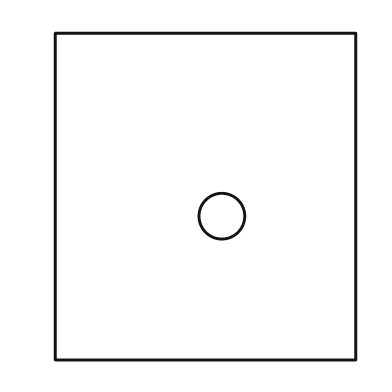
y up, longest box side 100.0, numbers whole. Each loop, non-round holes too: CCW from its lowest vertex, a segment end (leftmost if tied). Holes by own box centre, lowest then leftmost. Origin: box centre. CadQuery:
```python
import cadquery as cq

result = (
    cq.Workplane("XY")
    .moveTo(-46.0, -50.0)
    .lineTo(46.0, -50.0)
    .lineTo(46.0, 50.0)
    .lineTo(-46.0, 50.0)
    .close()
    .moveTo(5.0, -6.0)
    .circle(7.0)
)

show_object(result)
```